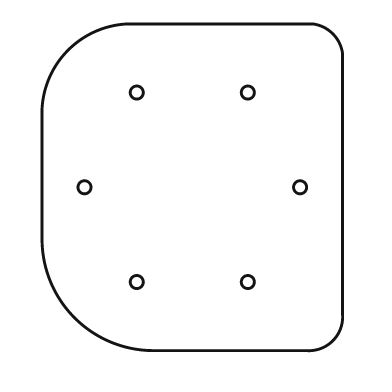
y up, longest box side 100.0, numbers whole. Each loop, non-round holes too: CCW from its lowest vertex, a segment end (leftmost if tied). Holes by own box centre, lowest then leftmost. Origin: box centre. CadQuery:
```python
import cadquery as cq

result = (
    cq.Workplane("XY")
    .moveTo(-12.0, -50.0)
    .lineTo(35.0, -50.0)
    .threePointArc((43.0, -47.0), (46.0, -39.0))
    .lineTo(46.0, 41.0)
    .threePointArc((43.0, 47.0), (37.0, 50.0))
    .lineTo(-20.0, 50.0)
    .threePointArc((-38.0, 42.0), (-46.0, 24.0))
    .lineTo(-46.0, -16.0)
    .threePointArc((-36.0, -40.0), (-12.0, -50.0))
    .close()
    .moveTo(-17.0, -29.0)
    .circle(2.0)
    .moveTo(17.0, -29.0)
    .circle(2.0)
    .moveTo(-33.0, 0.0)
    .circle(2.0)
    .moveTo(33.0, 0.0)
    .circle(2.0)
    .moveTo(-17.0, 29.0)
    .circle(2.0)
    .moveTo(17.0, 29.0)
    .circle(2.0)
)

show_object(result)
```